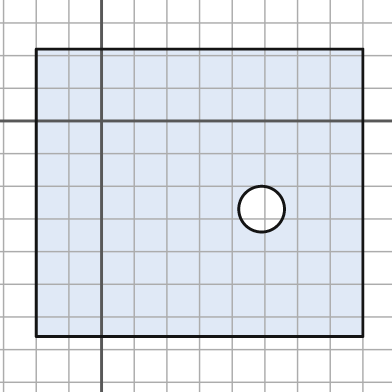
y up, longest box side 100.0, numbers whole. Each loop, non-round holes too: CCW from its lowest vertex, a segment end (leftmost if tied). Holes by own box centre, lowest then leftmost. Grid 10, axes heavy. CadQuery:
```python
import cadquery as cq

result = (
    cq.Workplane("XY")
    .moveTo(-20.0, -66.0)
    .lineTo(80.0, -66.0)
    .lineTo(80.0, 22.0)
    .lineTo(-20.0, 22.0)
    .close()
    .moveTo(49.0, -27.0)
    .circle(7.0)
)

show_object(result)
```